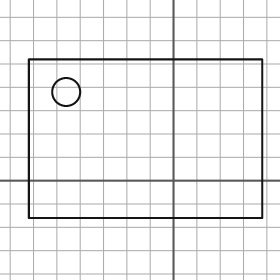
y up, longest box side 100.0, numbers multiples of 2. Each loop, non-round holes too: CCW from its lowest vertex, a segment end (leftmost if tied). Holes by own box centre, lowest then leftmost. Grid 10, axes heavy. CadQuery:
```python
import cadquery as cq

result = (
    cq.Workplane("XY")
    .moveTo(-62.0, -16.0)
    .lineTo(38.0, -16.0)
    .lineTo(38.0, 52.0)
    .lineTo(-62.0, 52.0)
    .close()
    .moveTo(-46.0, 38.0)
    .circle(6.0)
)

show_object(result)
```